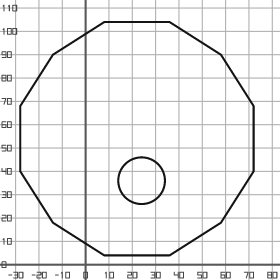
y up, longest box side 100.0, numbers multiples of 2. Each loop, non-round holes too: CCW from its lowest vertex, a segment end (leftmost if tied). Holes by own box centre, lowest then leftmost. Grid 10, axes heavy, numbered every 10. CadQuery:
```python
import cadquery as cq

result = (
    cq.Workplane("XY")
    .moveTo(8.0, 4.0)
    .lineTo(36.0, 4.0)
    .lineTo(58.0, 18.0)
    .lineTo(72.0, 40.0)
    .lineTo(72.0, 68.0)
    .lineTo(58.0, 90.0)
    .lineTo(36.0, 104.0)
    .lineTo(8.0, 104.0)
    .lineTo(-14.0, 90.0)
    .lineTo(-28.0, 68.0)
    .lineTo(-28.0, 40.0)
    .lineTo(-14.0, 18.0)
    .close()
    .moveTo(24.0, 36.0)
    .circle(10.0)
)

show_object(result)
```